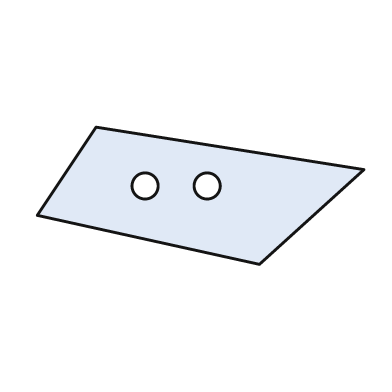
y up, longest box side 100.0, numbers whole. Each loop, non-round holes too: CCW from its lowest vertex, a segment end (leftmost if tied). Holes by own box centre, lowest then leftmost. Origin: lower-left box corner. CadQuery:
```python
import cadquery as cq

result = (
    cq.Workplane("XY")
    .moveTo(68.0, 0.0)
    .lineTo(100.0, 29.0)
    .lineTo(18.0, 42.0)
    .lineTo(0.0, 15.0)
    .close()
    .moveTo(33.0, 24.0)
    .circle(4.0)
    .moveTo(52.0, 24.0)
    .circle(4.0)
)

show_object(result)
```